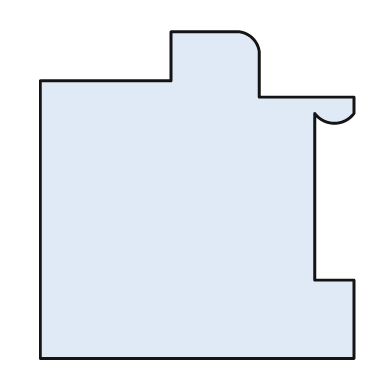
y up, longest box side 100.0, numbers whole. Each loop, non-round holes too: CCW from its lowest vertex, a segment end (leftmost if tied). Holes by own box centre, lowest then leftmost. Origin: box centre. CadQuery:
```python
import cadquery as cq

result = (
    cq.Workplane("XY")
    .moveTo(-48.0, -50.0)
    .lineTo(48.0, -50.0)
    .lineTo(48.0, -26.0)
    .lineTo(36.0, -26.0)
    .lineTo(36.0, 25.0)
    .threePointArc((42.0, 22.0), (48.0, 25.0))
    .lineTo(48.0, 30.0)
    .lineTo(19.0, 30.0)
    .lineTo(19.0, 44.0)
    .threePointArc((17.0, 48.0), (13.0, 50.0))
    .lineTo(-8.0, 50.0)
    .lineTo(-8.0, 35.0)
    .lineTo(-48.0, 35.0)
    .close()
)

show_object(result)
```